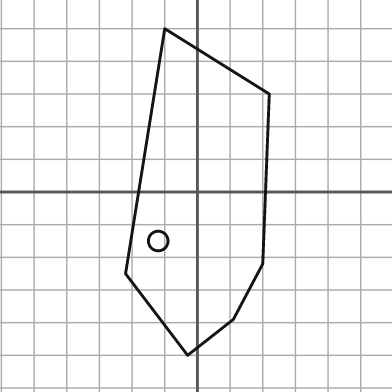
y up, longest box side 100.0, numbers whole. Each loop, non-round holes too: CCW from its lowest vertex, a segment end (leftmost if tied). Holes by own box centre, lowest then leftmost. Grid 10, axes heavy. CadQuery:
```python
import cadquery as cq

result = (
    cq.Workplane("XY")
    .moveTo(-3.0, -50.0)
    .lineTo(11.0, -39.0)
    .lineTo(20.0, -22.0)
    .lineTo(22.0, 30.0)
    .lineTo(-10.0, 50.0)
    .lineTo(-22.0, -25.0)
    .close()
    .moveTo(-12.0, -15.0)
    .circle(3.0)
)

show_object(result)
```